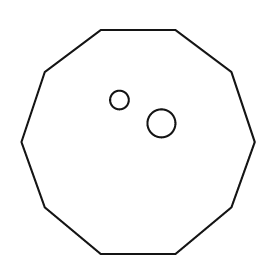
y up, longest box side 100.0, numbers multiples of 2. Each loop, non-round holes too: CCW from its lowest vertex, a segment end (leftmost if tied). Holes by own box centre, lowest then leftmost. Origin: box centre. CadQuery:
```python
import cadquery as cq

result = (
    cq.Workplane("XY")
    .moveTo(-16.0, -48.0)
    .lineTo(16.0, -48.0)
    .lineTo(40.0, -28.0)
    .lineTo(50.0, 0.0)
    .lineTo(40.0, 30.0)
    .lineTo(16.0, 48.0)
    .lineTo(-16.0, 48.0)
    .lineTo(-40.0, 30.0)
    .lineTo(-50.0, 0.0)
    .lineTo(-40.0, -28.0)
    .close()
    .moveTo(10.0, 8.0)
    .circle(6.0)
    .moveTo(-8.0, 18.0)
    .circle(4.0)
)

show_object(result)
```